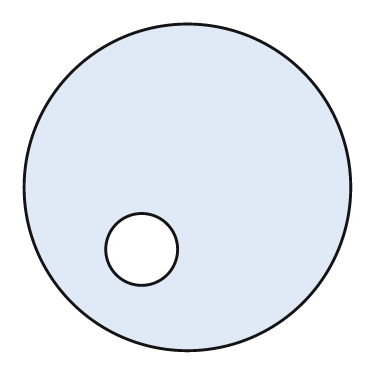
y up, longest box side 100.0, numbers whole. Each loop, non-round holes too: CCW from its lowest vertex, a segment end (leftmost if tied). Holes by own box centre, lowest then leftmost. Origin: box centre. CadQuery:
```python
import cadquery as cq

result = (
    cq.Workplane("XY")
    .moveTo(0.0, 0.0)
    .circle(50.0)
    .moveTo(-14.0, -19.0)
    .circle(11.0)
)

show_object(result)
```